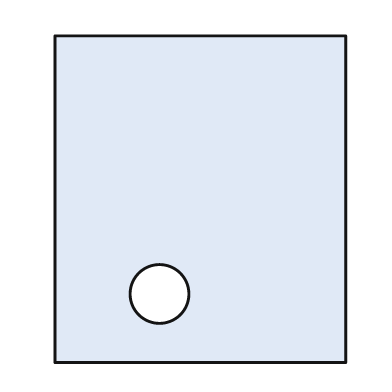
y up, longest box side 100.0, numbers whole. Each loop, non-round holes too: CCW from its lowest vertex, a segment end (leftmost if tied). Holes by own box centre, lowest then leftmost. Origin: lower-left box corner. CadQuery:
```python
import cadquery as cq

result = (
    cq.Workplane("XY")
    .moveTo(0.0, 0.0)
    .lineTo(89.0, 0.0)
    .lineTo(89.0, 100.0)
    .lineTo(0.0, 100.0)
    .close()
    .moveTo(32.0, 21.0)
    .circle(9.0)
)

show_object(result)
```